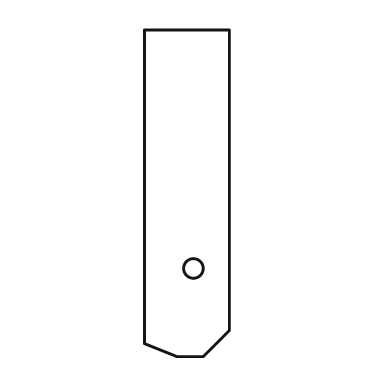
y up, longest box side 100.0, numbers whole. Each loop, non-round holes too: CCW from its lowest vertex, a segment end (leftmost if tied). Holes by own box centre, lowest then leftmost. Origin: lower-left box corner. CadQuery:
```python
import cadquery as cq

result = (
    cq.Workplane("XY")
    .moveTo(10.0, 0.0)
    .lineTo(18.0, 0.0)
    .lineTo(26.0, 8.0)
    .lineTo(26.0, 100.0)
    .lineTo(0.0, 100.0)
    .lineTo(0.0, 4.0)
    .close()
    .moveTo(15.0, 27.0)
    .circle(3.0)
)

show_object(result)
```